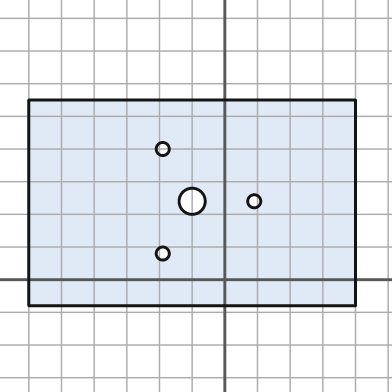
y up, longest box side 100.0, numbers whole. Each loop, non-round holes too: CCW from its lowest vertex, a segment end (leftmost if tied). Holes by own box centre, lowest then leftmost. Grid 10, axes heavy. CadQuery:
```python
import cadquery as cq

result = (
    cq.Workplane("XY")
    .moveTo(-60.0, -8.0)
    .lineTo(40.0, -8.0)
    .lineTo(40.0, 55.0)
    .lineTo(-60.0, 55.0)
    .close()
    .moveTo(-19.0, 8.0)
    .circle(2.0)
    .moveTo(-10.0, 24.0)
    .circle(4.0)
    .moveTo(9.0, 24.0)
    .circle(2.0)
    .moveTo(-19.0, 40.0)
    .circle(2.0)
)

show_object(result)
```